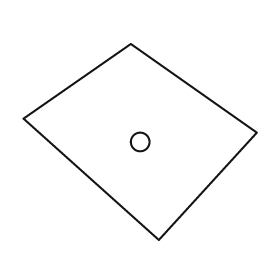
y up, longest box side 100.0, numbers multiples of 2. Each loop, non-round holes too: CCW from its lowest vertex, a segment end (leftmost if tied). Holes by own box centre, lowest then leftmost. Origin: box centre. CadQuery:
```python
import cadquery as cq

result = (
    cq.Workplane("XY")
    .moveTo(8.0, -42.0)
    .lineTo(50.0, 4.0)
    .lineTo(-4.0, 42.0)
    .lineTo(-50.0, 10.0)
    .close()
    .moveTo(0.0, 0.0)
    .circle(4.0)
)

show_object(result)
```